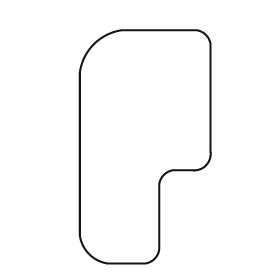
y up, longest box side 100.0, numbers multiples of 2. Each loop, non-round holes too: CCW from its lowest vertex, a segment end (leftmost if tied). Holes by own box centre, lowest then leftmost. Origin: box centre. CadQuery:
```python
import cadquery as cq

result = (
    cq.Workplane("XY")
    .moveTo(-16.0, -50.0)
    .lineTo(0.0, -50.0)
    .threePointArc((4.0, -48.0), (6.0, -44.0))
    .lineTo(6.0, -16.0)
    .threePointArc((8.0, -12.0), (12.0, -10.0))
    .lineTo(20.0, -10.0)
    .threePointArc((26.0, -8.0), (28.0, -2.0))
    .lineTo(28.0, 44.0)
    .threePointArc((26.0, 48.0), (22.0, 50.0))
    .lineTo(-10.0, 50.0)
    .threePointArc((-22.0, 44.0), (-28.0, 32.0))
    .lineTo(-28.0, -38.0)
    .threePointArc((-24.0, -46.0), (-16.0, -50.0))
    .close()
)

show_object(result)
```